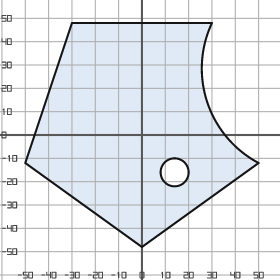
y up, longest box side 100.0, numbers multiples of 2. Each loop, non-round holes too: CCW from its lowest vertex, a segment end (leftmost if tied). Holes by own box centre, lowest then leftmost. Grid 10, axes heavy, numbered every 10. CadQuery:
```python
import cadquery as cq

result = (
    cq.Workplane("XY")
    .moveTo(0.0, -48.0)
    .lineTo(50.0, -12.0)
    .threePointArc((28.0, 14.0), (30.0, 48.0))
    .lineTo(-30.0, 48.0)
    .lineTo(-50.0, -12.0)
    .close()
    .moveTo(14.0, -16.0)
    .circle(6.0)
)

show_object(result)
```